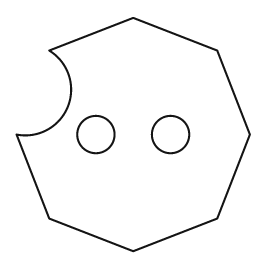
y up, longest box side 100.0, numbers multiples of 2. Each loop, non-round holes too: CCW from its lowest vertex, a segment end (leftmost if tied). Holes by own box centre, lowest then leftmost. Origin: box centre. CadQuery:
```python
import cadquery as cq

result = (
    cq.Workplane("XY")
    .moveTo(0.0, -50.0)
    .lineTo(36.0, -36.0)
    .lineTo(50.0, 0.0)
    .lineTo(36.0, 36.0)
    .lineTo(0.0, 50.0)
    .lineTo(-36.0, 36.0)
    .threePointArc((-28.0, 12.0), (-50.0, 0.0))
    .lineTo(-36.0, -36.0)
    .close()
    .moveTo(-16.0, 0.0)
    .circle(8.0)
    .moveTo(16.0, 0.0)
    .circle(8.0)
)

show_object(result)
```